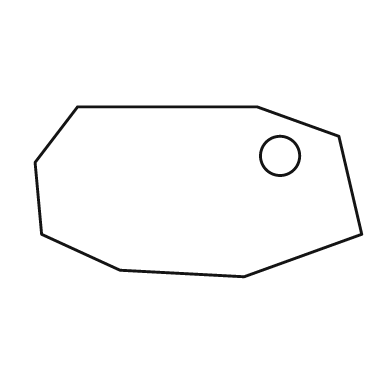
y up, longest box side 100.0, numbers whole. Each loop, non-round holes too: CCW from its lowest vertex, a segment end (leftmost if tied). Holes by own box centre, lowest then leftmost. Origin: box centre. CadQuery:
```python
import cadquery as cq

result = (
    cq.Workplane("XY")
    .moveTo(14.0, -26.0)
    .lineTo(50.0, -13.0)
    .lineTo(43.0, 17.0)
    .lineTo(18.0, 26.0)
    .lineTo(-37.0, 26.0)
    .lineTo(-50.0, 9.0)
    .lineTo(-48.0, -13.0)
    .lineTo(-24.0, -24.0)
    .close()
    .moveTo(25.0, 11.0)
    .circle(6.0)
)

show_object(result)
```